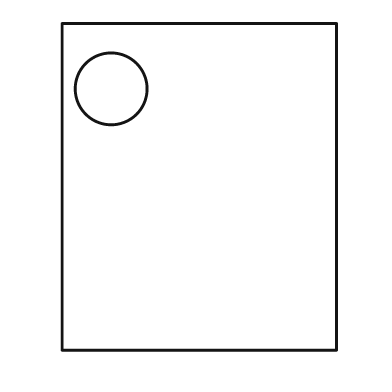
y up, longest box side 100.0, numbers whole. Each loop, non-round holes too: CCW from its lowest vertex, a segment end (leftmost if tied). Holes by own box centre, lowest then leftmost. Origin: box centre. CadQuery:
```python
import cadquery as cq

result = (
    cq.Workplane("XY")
    .moveTo(-42.0, -50.0)
    .lineTo(42.0, -50.0)
    .lineTo(42.0, 50.0)
    .lineTo(-42.0, 50.0)
    .close()
    .moveTo(-27.0, 30.0)
    .circle(11.0)
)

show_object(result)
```